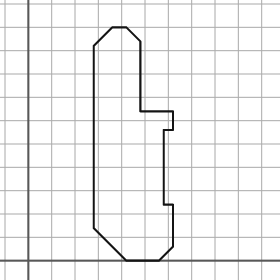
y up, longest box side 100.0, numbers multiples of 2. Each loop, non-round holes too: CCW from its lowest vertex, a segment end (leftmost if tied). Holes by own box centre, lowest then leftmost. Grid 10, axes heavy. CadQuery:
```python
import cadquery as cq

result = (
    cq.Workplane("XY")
    .moveTo(42.0, 0.0)
    .lineTo(56.0, 0.0)
    .lineTo(62.0, 6.0)
    .lineTo(62.0, 24.0)
    .lineTo(58.0, 24.0)
    .lineTo(58.0, 56.0)
    .lineTo(62.0, 56.0)
    .lineTo(62.0, 64.0)
    .lineTo(48.0, 64.0)
    .lineTo(48.0, 94.0)
    .lineTo(42.0, 100.0)
    .lineTo(36.0, 100.0)
    .lineTo(28.0, 92.0)
    .lineTo(28.0, 14.0)
    .close()
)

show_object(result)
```